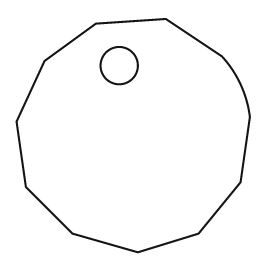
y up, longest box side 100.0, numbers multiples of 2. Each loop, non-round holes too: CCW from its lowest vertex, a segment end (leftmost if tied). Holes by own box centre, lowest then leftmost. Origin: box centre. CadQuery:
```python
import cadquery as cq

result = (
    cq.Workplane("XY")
    .moveTo(2.0, -50.0)
    .lineTo(28.0, -42.0)
    .lineTo(46.0, -20.0)
    .lineTo(50.0, 8.0)
    .threePointArc((46.0, 22.0), (38.0, 34.0))
    .lineTo(14.0, 50.0)
    .lineTo(-16.0, 48.0)
    .lineTo(-38.0, 32.0)
    .lineTo(-50.0, 6.0)
    .lineTo(-46.0, -22.0)
    .lineTo(-26.0, -42.0)
    .close()
    .moveTo(-6.0, 30.0)
    .circle(8.0)
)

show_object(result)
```